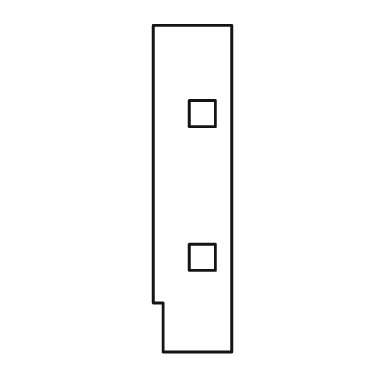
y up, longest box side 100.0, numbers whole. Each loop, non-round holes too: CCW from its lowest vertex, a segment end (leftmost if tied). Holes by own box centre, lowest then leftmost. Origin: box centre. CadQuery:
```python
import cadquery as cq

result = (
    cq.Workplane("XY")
    .moveTo(-9.0, -50.0)
    .lineTo(12.0, -50.0)
    .lineTo(12.0, 50.0)
    .lineTo(-12.0, 50.0)
    .lineTo(-12.0, -35.0)
    .lineTo(-9.0, -35.0)
    .close()
    .moveTo(-1.0, -25.0)
    .lineTo(7.0, -25.0)
    .lineTo(7.0, -17.0)
    .lineTo(-1.0, -17.0)
    .close()
    .moveTo(-1.0, 19.0)
    .lineTo(7.0, 19.0)
    .lineTo(7.0, 27.0)
    .lineTo(-1.0, 27.0)
    .close()
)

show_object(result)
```